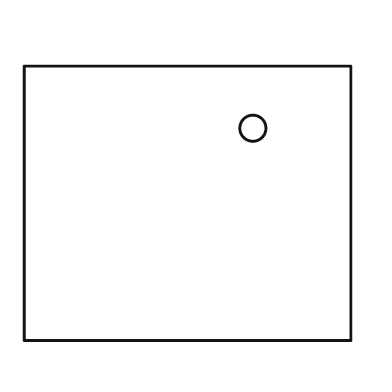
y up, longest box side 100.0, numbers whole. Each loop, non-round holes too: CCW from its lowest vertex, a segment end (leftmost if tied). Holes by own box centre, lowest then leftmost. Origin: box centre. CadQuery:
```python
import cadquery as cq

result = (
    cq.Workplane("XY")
    .moveTo(-50.0, -42.0)
    .lineTo(50.0, -42.0)
    .lineTo(50.0, 42.0)
    .lineTo(-50.0, 42.0)
    .close()
    .moveTo(20.0, 23.0)
    .circle(4.0)
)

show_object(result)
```